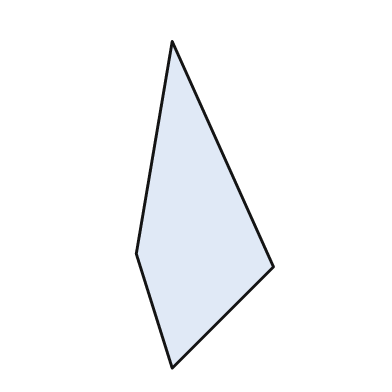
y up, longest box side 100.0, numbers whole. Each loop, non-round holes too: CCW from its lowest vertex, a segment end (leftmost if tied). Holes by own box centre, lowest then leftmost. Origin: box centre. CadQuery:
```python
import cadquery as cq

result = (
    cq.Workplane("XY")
    .moveTo(-10.0, -50.0)
    .lineTo(21.0, -19.0)
    .lineTo(-10.0, 50.0)
    .lineTo(-21.0, -15.0)
    .close()
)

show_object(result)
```